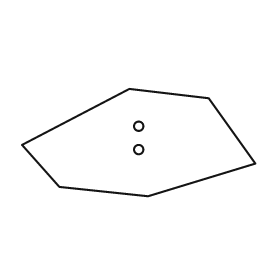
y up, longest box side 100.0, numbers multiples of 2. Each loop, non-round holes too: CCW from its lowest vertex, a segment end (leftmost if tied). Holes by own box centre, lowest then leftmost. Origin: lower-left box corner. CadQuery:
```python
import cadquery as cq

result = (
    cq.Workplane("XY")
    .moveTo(54.0, 0.0)
    .lineTo(100.0, 14.0)
    .lineTo(80.0, 42.0)
    .lineTo(46.0, 46.0)
    .lineTo(0.0, 22.0)
    .lineTo(16.0, 4.0)
    .close()
    .moveTo(50.0, 20.0)
    .circle(2.0)
    .moveTo(50.0, 30.0)
    .circle(2.0)
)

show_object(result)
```